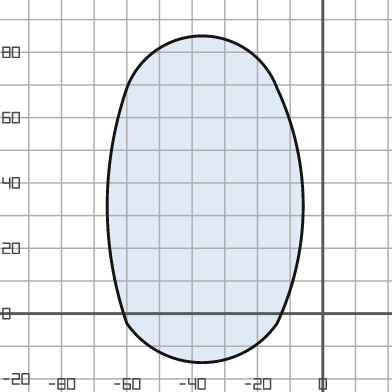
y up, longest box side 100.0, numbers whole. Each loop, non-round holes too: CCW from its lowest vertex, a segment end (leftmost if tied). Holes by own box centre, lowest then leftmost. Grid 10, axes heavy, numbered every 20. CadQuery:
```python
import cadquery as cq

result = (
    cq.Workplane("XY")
    .moveTo(-60.0, -3.0)
    .threePointArc((-37.0, -15.0), (-14.0, -3.0))
    .threePointArc((-6.0, 33.0), (-14.0, 69.0))
    .threePointArc((-37.0, 85.0), (-60.0, 69.0))
    .threePointArc((-66.0, 33.0), (-60.0, -3.0))
    .close()
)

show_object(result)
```